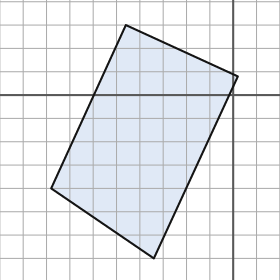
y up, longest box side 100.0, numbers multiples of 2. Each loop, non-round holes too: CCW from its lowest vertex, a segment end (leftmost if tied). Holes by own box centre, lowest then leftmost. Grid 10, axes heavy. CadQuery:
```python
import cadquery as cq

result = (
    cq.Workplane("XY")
    .moveTo(-34.0, -70.0)
    .lineTo(2.0, 8.0)
    .lineTo(-46.0, 30.0)
    .lineTo(-78.0, -40.0)
    .close()
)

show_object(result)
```